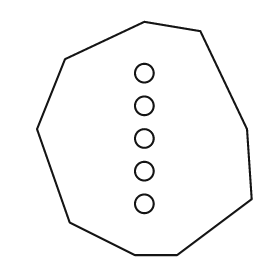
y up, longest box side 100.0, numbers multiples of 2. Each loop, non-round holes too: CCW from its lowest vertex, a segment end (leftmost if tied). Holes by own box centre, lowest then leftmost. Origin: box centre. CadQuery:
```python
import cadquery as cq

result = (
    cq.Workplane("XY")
    .moveTo(-4.0, -50.0)
    .lineTo(14.0, -50.0)
    .lineTo(46.0, -26.0)
    .lineTo(44.0, 4.0)
    .lineTo(24.0, 46.0)
    .lineTo(0.0, 50.0)
    .lineTo(-34.0, 34.0)
    .lineTo(-46.0, 4.0)
    .lineTo(-32.0, -36.0)
    .close()
    .moveTo(0.0, -28.0)
    .circle(4.0)
    .moveTo(0.0, -14.0)
    .circle(4.0)
    .moveTo(0.0, 0.0)
    .circle(4.0)
    .moveTo(0.0, 14.0)
    .circle(4.0)
    .moveTo(0.0, 28.0)
    .circle(4.0)
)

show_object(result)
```